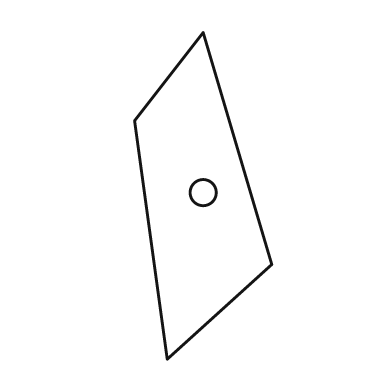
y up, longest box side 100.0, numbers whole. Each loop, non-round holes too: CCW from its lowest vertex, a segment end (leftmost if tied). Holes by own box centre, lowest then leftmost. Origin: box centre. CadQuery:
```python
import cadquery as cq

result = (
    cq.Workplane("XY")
    .moveTo(-11.0, -50.0)
    .lineTo(21.0, -21.0)
    .lineTo(0.0, 50.0)
    .lineTo(-21.0, 23.0)
    .close()
    .moveTo(0.0, 1.0)
    .circle(4.0)
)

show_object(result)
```